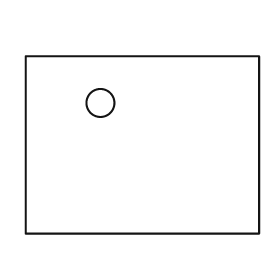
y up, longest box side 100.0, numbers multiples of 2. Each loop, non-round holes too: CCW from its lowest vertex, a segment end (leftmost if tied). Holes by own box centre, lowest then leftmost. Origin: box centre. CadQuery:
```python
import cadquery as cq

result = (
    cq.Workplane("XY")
    .moveTo(-50.0, -38.0)
    .lineTo(50.0, -38.0)
    .lineTo(50.0, 38.0)
    .lineTo(-50.0, 38.0)
    .close()
    .moveTo(-18.0, 18.0)
    .circle(6.0)
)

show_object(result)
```